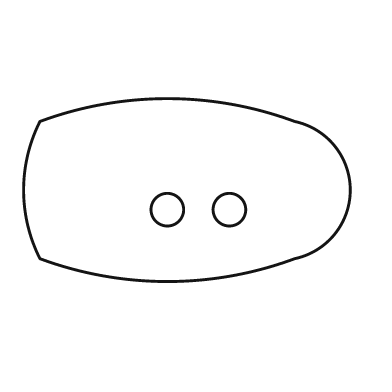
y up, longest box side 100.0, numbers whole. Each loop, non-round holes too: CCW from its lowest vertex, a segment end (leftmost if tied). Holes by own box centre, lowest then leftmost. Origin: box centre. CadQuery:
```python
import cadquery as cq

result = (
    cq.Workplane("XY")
    .moveTo(-45.0, -21.0)
    .threePointArc((-6.0, -28.0), (33.0, -21.0))
    .threePointArc((50.0, 0.0), (33.0, 21.0))
    .threePointArc((-6.0, 28.0), (-45.0, 21.0))
    .threePointArc((-50.0, 0.0), (-45.0, -21.0))
    .close()
    .moveTo(-6.0, -6.0)
    .circle(5.0)
    .moveTo(13.0, -6.0)
    .circle(5.0)
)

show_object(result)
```